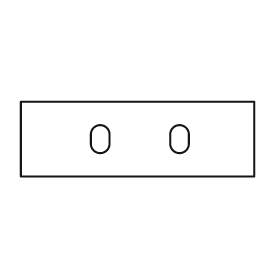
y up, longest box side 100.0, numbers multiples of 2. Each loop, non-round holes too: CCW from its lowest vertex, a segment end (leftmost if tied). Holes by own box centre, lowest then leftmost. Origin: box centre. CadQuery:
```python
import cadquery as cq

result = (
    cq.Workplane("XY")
    .moveTo(-50.0, -16.0)
    .lineTo(50.0, -16.0)
    .lineTo(50.0, 16.0)
    .lineTo(-50.0, 16.0)
    .close()
    .moveTo(-20.0, -2.0)
    .threePointArc((-16.0, -6.0), (-12.0, -2.0))
    .lineTo(-12.0, 2.0)
    .threePointArc((-16.0, 6.0), (-20.0, 2.0))
    .close()
    .moveTo(14.0, -2.0)
    .threePointArc((18.0, -6.0), (22.0, -2.0))
    .lineTo(22.0, 2.0)
    .threePointArc((18.0, 6.0), (14.0, 2.0))
    .close()
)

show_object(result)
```